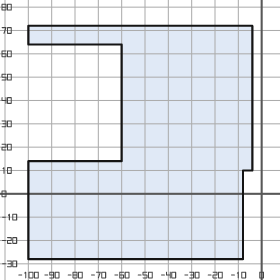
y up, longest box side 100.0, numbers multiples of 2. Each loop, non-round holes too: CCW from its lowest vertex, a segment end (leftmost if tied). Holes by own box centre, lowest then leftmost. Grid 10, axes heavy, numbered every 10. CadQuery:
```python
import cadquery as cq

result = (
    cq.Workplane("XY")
    .moveTo(-100.0, -28.0)
    .lineTo(-8.0, -28.0)
    .lineTo(-8.0, 10.0)
    .lineTo(-4.0, 10.0)
    .lineTo(-4.0, 72.0)
    .lineTo(-100.0, 72.0)
    .lineTo(-100.0, 64.0)
    .lineTo(-60.0, 64.0)
    .lineTo(-60.0, 14.0)
    .lineTo(-100.0, 14.0)
    .close()
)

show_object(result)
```